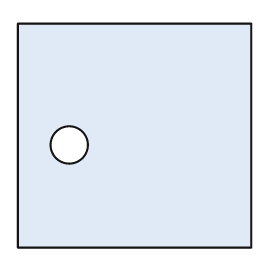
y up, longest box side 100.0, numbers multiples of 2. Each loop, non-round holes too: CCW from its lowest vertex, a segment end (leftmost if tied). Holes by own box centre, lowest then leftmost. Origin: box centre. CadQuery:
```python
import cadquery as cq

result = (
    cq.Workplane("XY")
    .moveTo(-50.0, -48.0)
    .lineTo(50.0, -48.0)
    .lineTo(50.0, 48.0)
    .lineTo(-50.0, 48.0)
    .close()
    .moveTo(-28.0, -4.0)
    .circle(8.0)
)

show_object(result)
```